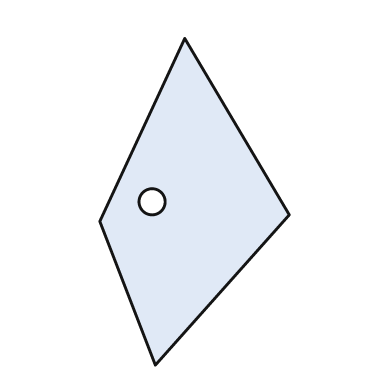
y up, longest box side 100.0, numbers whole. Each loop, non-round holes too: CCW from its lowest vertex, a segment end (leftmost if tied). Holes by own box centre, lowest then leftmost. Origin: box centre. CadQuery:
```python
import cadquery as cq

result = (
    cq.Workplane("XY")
    .moveTo(-12.0, -50.0)
    .lineTo(29.0, -4.0)
    .lineTo(-3.0, 50.0)
    .lineTo(-29.0, -6.0)
    .close()
    .moveTo(-13.0, 0.0)
    .circle(4.0)
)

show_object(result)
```